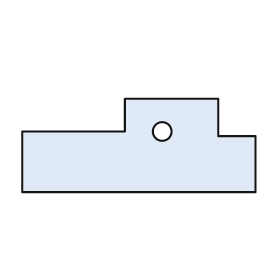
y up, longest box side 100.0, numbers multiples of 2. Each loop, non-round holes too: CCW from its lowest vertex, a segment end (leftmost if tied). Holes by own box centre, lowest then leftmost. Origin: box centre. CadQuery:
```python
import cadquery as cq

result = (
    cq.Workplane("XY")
    .moveTo(-50.0, -20.0)
    .lineTo(50.0, -20.0)
    .lineTo(50.0, 4.0)
    .lineTo(34.0, 4.0)
    .lineTo(34.0, 20.0)
    .lineTo(-6.0, 20.0)
    .lineTo(-6.0, 6.0)
    .lineTo(-50.0, 6.0)
    .close()
    .moveTo(10.0, 6.0)
    .circle(4.0)
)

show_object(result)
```